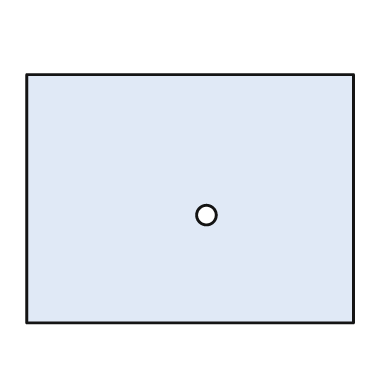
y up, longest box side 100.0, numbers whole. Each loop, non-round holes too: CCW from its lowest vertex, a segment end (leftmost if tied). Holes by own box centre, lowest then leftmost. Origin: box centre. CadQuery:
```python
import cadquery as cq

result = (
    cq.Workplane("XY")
    .moveTo(-50.0, -38.0)
    .lineTo(50.0, -38.0)
    .lineTo(50.0, 38.0)
    .lineTo(-50.0, 38.0)
    .close()
    .moveTo(5.0, -5.0)
    .circle(3.0)
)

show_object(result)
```